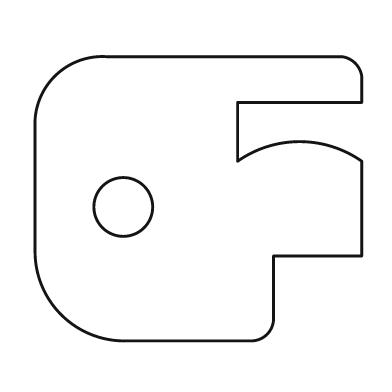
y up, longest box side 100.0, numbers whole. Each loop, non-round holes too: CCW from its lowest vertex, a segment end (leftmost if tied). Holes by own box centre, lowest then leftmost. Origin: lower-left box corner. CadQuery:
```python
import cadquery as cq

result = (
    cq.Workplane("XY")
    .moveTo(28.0, 0.0)
    .lineTo(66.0, 0.0)
    .threePointArc((71.0, 2.0), (73.0, 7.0))
    .lineTo(73.0, 26.0)
    .lineTo(100.0, 26.0)
    .lineTo(100.0, 55.0)
    .threePointArc((81.0, 61.0), (62.0, 55.0))
    .lineTo(62.0, 73.0)
    .lineTo(100.0, 73.0)
    .lineTo(100.0, 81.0)
    .threePointArc((98.0, 85.0), (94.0, 87.0))
    .lineTo(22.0, 87.0)
    .threePointArc((6.0, 81.0), (0.0, 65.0))
    .lineTo(0.0, 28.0)
    .threePointArc((8.0, 8.0), (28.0, 0.0))
    .close()
    .moveTo(27.0, 41.0)
    .circle(9.0)
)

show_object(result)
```